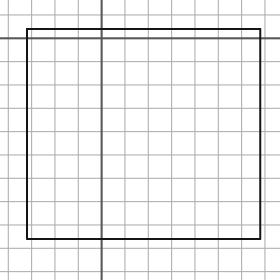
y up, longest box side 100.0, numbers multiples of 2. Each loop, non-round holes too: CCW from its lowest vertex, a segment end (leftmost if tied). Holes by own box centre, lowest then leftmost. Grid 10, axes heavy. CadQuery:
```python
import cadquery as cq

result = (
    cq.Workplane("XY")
    .moveTo(-32.0, -86.0)
    .lineTo(68.0, -86.0)
    .lineTo(68.0, 4.0)
    .lineTo(-32.0, 4.0)
    .close()
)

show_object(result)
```